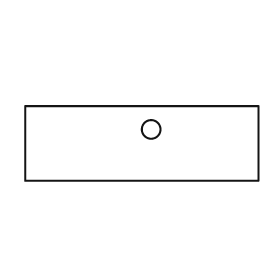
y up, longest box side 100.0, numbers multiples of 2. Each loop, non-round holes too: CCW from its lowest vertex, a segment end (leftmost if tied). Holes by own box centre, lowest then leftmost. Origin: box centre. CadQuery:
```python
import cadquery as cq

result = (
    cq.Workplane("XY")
    .moveTo(-50.0, -16.0)
    .lineTo(50.0, -16.0)
    .lineTo(50.0, 16.0)
    .lineTo(-50.0, 16.0)
    .close()
    .moveTo(4.0, 6.0)
    .circle(4.0)
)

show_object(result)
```